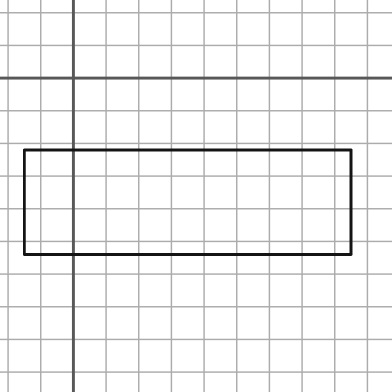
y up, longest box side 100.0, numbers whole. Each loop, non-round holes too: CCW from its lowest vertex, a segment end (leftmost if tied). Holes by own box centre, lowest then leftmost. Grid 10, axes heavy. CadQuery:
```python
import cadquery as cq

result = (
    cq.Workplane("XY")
    .moveTo(-15.0, -54.0)
    .lineTo(85.0, -54.0)
    .lineTo(85.0, -22.0)
    .lineTo(-15.0, -22.0)
    .close()
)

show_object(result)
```